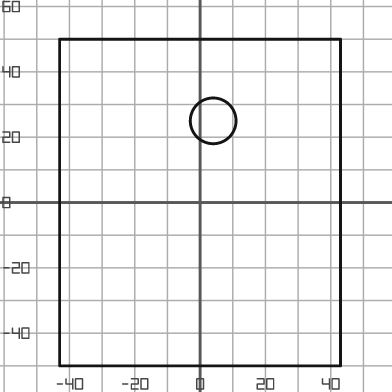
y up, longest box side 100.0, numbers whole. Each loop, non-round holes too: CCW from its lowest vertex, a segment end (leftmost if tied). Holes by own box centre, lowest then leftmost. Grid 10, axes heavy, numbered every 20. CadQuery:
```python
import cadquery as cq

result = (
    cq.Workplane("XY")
    .moveTo(-43.0, -50.0)
    .lineTo(43.0, -50.0)
    .lineTo(43.0, 50.0)
    .lineTo(-43.0, 50.0)
    .close()
    .moveTo(4.0, 25.0)
    .circle(7.0)
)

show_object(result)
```